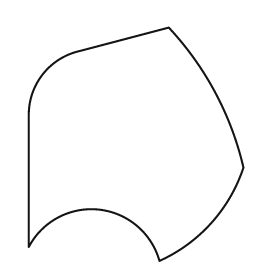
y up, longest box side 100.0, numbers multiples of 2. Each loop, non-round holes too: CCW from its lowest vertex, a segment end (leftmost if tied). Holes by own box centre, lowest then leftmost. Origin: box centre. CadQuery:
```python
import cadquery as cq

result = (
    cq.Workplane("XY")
    .moveTo(10.0, -50.0)
    .threePointArc((32.0, -34.0), (46.0, -10.0))
    .threePointArc((34.0, 22.0), (14.0, 50.0))
    .lineTo(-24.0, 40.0)
    .threePointArc((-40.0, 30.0), (-46.0, 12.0))
    .lineTo(-46.0, -44.0)
    .threePointArc((-16.0, -28.0), (10.0, -50.0))
    .close()
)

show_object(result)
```